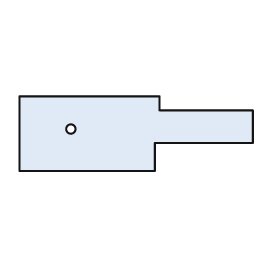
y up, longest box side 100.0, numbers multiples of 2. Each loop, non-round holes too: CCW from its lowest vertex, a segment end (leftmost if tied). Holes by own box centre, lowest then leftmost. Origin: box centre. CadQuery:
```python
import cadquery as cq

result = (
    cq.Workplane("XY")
    .moveTo(-50.0, -16.0)
    .lineTo(8.0, -16.0)
    .lineTo(8.0, -4.0)
    .lineTo(50.0, -4.0)
    .lineTo(50.0, 10.0)
    .lineTo(10.0, 10.0)
    .lineTo(10.0, 16.0)
    .lineTo(-50.0, 16.0)
    .close()
    .moveTo(-28.0, 2.0)
    .circle(2.0)
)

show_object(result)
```